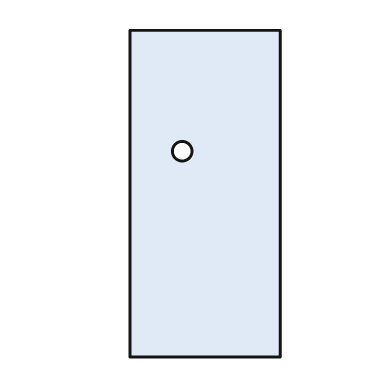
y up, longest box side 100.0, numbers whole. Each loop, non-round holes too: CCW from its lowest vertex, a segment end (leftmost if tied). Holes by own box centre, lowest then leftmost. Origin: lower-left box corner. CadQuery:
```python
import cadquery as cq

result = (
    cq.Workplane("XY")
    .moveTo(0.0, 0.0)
    .lineTo(46.0, 0.0)
    .lineTo(46.0, 100.0)
    .lineTo(0.0, 100.0)
    .close()
    .moveTo(16.0, 63.0)
    .circle(3.0)
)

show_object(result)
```